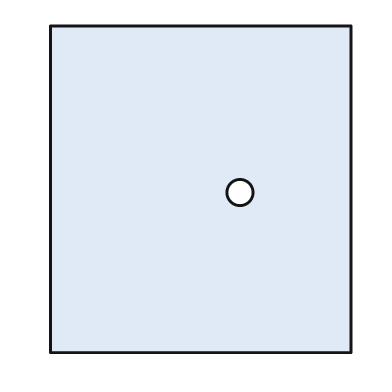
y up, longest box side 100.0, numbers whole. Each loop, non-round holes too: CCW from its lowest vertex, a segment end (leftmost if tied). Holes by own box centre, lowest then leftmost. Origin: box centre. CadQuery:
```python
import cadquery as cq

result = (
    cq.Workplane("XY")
    .moveTo(-46.0, -50.0)
    .lineTo(46.0, -50.0)
    .lineTo(46.0, 50.0)
    .lineTo(-46.0, 50.0)
    .close()
    .moveTo(12.0, -1.0)
    .circle(4.0)
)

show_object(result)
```